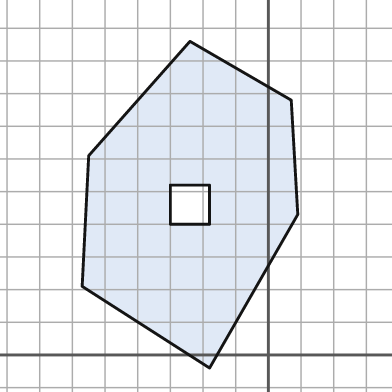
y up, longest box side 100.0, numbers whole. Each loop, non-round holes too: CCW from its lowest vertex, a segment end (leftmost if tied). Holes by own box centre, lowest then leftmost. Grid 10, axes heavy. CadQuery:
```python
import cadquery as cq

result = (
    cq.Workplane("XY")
    .moveTo(-18.0, -4.0)
    .lineTo(9.0, 43.0)
    .lineTo(7.0, 78.0)
    .lineTo(-24.0, 96.0)
    .lineTo(-55.0, 61.0)
    .lineTo(-57.0, 21.0)
    .close()
    .moveTo(-30.0, 40.0)
    .lineTo(-18.0, 40.0)
    .lineTo(-18.0, 52.0)
    .lineTo(-30.0, 52.0)
    .close()
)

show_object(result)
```